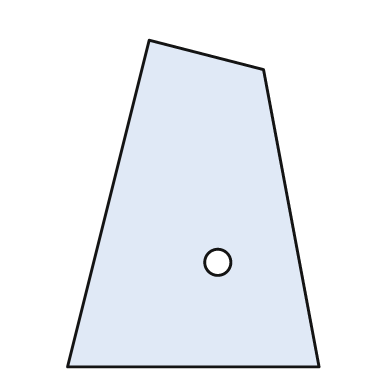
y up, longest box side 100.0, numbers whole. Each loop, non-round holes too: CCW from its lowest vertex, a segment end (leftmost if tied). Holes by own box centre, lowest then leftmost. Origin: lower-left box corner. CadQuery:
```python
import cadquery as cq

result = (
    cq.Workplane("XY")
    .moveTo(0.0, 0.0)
    .lineTo(77.0, 0.0)
    .lineTo(60.0, 91.0)
    .lineTo(25.0, 100.0)
    .close()
    .moveTo(46.0, 32.0)
    .circle(4.0)
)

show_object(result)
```